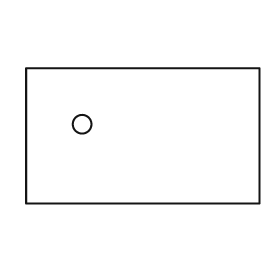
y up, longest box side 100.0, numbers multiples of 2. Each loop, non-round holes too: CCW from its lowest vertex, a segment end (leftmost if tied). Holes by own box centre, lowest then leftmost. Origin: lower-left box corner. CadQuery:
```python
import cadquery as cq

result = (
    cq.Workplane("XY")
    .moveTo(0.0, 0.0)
    .lineTo(100.0, 0.0)
    .lineTo(100.0, 58.0)
    .lineTo(0.0, 58.0)
    .close()
    .moveTo(24.0, 34.0)
    .circle(4.0)
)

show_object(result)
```